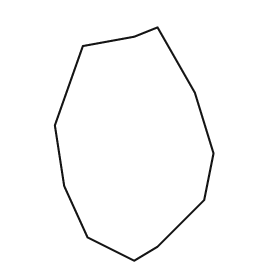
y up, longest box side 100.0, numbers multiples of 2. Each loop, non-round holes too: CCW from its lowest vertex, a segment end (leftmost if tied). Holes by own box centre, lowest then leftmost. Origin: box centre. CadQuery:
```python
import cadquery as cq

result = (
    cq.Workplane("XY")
    .moveTo(0.0, -50.0)
    .lineTo(10.0, -44.0)
    .lineTo(30.0, -24.0)
    .lineTo(34.0, -4.0)
    .lineTo(26.0, 22.0)
    .lineTo(10.0, 50.0)
    .lineTo(0.0, 46.0)
    .lineTo(-22.0, 42.0)
    .lineTo(-34.0, 8.0)
    .lineTo(-30.0, -18.0)
    .lineTo(-20.0, -40.0)
    .close()
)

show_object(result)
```